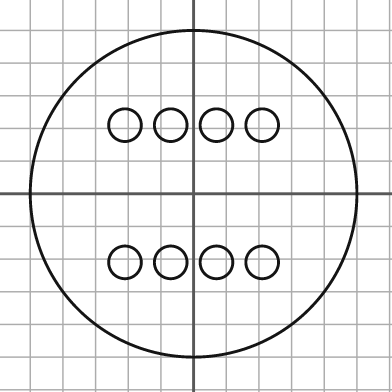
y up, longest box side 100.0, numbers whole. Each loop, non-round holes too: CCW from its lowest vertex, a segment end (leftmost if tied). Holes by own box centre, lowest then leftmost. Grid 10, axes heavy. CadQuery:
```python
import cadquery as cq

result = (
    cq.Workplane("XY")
    .moveTo(0.0, 0.0)
    .circle(50.0)
    .moveTo(-21.0, -21.0)
    .circle(5.0)
    .moveTo(-7.0, -21.0)
    .circle(5.0)
    .moveTo(7.0, -21.0)
    .circle(5.0)
    .moveTo(21.0, -21.0)
    .circle(5.0)
    .moveTo(-21.0, 21.0)
    .circle(5.0)
    .moveTo(-7.0, 21.0)
    .circle(5.0)
    .moveTo(7.0, 21.0)
    .circle(5.0)
    .moveTo(21.0, 21.0)
    .circle(5.0)
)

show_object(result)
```